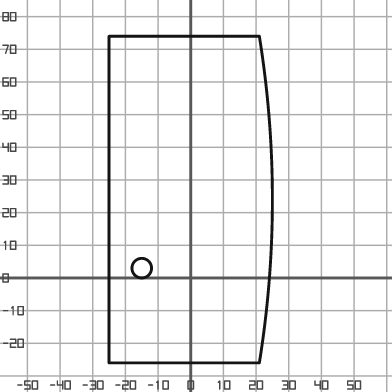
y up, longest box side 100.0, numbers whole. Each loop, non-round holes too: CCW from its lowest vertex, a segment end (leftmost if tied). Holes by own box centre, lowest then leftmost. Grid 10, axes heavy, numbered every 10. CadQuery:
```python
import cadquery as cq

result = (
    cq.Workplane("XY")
    .moveTo(-25.0, -26.0)
    .lineTo(21.0, -26.0)
    .threePointArc((25.0, 24.0), (21.0, 74.0))
    .lineTo(-25.0, 74.0)
    .close()
    .moveTo(-15.0, 3.0)
    .circle(3.0)
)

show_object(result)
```